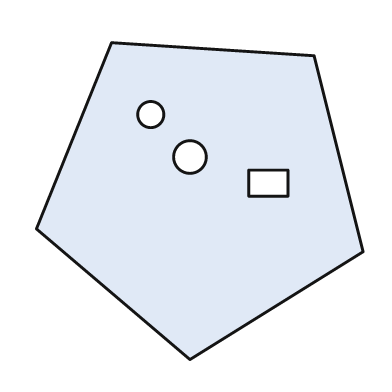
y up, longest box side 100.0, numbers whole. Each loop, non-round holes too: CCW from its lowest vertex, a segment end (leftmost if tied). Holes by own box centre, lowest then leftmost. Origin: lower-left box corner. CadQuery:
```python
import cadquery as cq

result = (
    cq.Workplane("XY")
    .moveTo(47.0, 0.0)
    .lineTo(100.0, 33.0)
    .lineTo(85.0, 93.0)
    .lineTo(23.0, 97.0)
    .lineTo(0.0, 40.0)
    .close()
    .moveTo(65.0, 50.0)
    .lineTo(77.0, 50.0)
    .lineTo(77.0, 58.0)
    .lineTo(65.0, 58.0)
    .close()
    .moveTo(47.0, 62.0)
    .circle(5.0)
    .moveTo(35.0, 75.0)
    .circle(4.0)
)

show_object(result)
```